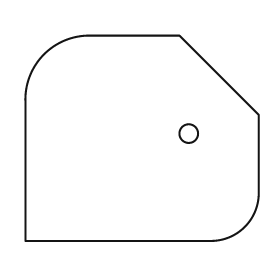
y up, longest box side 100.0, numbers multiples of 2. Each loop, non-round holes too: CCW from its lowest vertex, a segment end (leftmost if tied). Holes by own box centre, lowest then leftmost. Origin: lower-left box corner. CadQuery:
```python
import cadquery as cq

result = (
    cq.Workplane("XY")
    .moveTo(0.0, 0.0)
    .lineTo(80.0, 0.0)
    .threePointArc((94.0, 6.0), (100.0, 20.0))
    .lineTo(100.0, 54.0)
    .lineTo(66.0, 88.0)
    .lineTo(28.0, 88.0)
    .threePointArc((8.0, 80.0), (0.0, 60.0))
    .close()
    .moveTo(70.0, 46.0)
    .circle(4.0)
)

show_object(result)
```